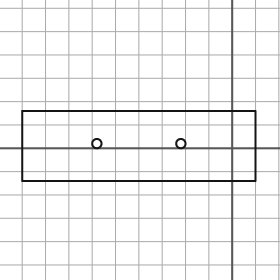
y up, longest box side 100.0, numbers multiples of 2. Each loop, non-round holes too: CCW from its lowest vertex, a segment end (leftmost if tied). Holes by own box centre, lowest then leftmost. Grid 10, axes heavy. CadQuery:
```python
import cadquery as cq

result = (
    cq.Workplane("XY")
    .moveTo(-90.0, -14.0)
    .lineTo(10.0, -14.0)
    .lineTo(10.0, 16.0)
    .lineTo(-90.0, 16.0)
    .close()
    .moveTo(-58.0, 2.0)
    .circle(2.0)
    .moveTo(-22.0, 2.0)
    .circle(2.0)
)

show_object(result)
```